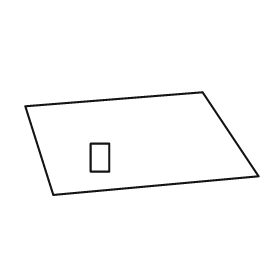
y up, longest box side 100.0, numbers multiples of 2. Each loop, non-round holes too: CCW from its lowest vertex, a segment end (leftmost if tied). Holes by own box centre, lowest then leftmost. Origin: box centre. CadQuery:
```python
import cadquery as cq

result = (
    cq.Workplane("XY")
    .moveTo(-38.0, -22.0)
    .lineTo(50.0, -14.0)
    .lineTo(26.0, 22.0)
    .lineTo(-50.0, 16.0)
    .close()
    .moveTo(-22.0, -12.0)
    .lineTo(-14.0, -12.0)
    .lineTo(-14.0, 0.0)
    .lineTo(-22.0, 0.0)
    .close()
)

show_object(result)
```